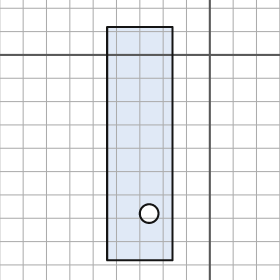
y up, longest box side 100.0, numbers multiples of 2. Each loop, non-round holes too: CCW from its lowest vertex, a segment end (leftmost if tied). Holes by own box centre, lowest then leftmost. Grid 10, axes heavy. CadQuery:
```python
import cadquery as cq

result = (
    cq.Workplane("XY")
    .moveTo(-44.0, -88.0)
    .lineTo(-16.0, -88.0)
    .lineTo(-16.0, 12.0)
    .lineTo(-44.0, 12.0)
    .close()
    .moveTo(-26.0, -68.0)
    .circle(4.0)
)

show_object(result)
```